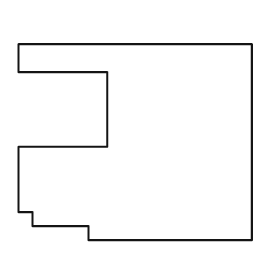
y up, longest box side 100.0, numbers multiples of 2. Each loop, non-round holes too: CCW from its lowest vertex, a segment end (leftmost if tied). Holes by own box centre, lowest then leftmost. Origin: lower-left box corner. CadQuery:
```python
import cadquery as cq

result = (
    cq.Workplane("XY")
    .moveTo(30.0, 0.0)
    .lineTo(100.0, 0.0)
    .lineTo(100.0, 84.0)
    .lineTo(0.0, 84.0)
    .lineTo(0.0, 72.0)
    .lineTo(38.0, 72.0)
    .lineTo(38.0, 40.0)
    .lineTo(0.0, 40.0)
    .lineTo(0.0, 12.0)
    .lineTo(6.0, 12.0)
    .lineTo(6.0, 6.0)
    .lineTo(30.0, 6.0)
    .close()
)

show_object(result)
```